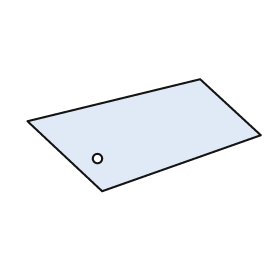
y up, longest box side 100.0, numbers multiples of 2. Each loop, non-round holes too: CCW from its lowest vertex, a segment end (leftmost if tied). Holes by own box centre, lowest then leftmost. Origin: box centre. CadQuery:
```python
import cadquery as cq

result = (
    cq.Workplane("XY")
    .moveTo(-18.0, -24.0)
    .lineTo(50.0, 0.0)
    .lineTo(24.0, 24.0)
    .lineTo(-50.0, 6.0)
    .close()
    .moveTo(-20.0, -10.0)
    .circle(2.0)
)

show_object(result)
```